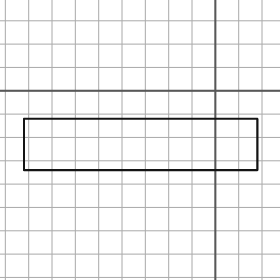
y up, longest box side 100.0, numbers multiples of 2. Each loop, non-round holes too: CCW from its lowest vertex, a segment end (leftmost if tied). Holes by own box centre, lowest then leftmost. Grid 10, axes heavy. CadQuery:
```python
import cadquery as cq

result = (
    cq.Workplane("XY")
    .moveTo(-82.0, -34.0)
    .lineTo(18.0, -34.0)
    .lineTo(18.0, -12.0)
    .lineTo(-82.0, -12.0)
    .close()
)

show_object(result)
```